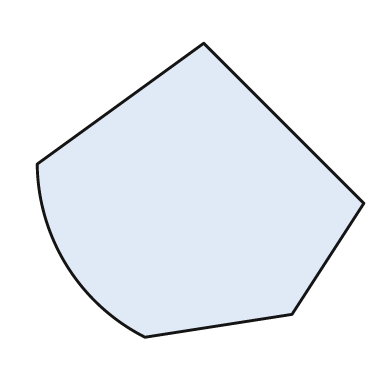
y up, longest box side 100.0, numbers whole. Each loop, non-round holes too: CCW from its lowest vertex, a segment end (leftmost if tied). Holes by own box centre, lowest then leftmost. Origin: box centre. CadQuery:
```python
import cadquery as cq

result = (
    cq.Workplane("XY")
    .moveTo(-17.0, -45.0)
    .lineTo(28.0, -38.0)
    .lineTo(50.0, -4.0)
    .lineTo(1.0, 45.0)
    .lineTo(-50.0, 8.0)
    .threePointArc((-41.0, -23.0), (-17.0, -45.0))
    .close()
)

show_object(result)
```